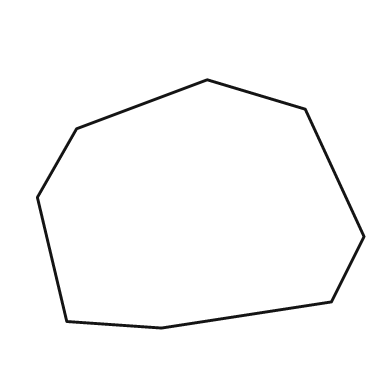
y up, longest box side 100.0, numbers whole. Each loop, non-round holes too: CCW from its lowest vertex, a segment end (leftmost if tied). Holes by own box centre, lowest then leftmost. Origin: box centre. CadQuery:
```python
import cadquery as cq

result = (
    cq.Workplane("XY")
    .moveTo(-12.0, -38.0)
    .lineTo(40.0, -30.0)
    .lineTo(50.0, -10.0)
    .lineTo(32.0, 29.0)
    .lineTo(2.0, 38.0)
    .lineTo(-38.0, 23.0)
    .lineTo(-50.0, 2.0)
    .lineTo(-41.0, -36.0)
    .close()
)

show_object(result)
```